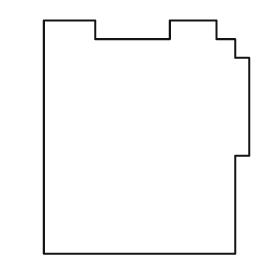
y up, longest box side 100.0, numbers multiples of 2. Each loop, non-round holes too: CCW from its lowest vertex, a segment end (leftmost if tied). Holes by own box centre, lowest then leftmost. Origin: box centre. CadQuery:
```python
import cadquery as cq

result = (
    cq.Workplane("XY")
    .moveTo(-44.0, -50.0)
    .lineTo(38.0, -50.0)
    .lineTo(38.0, -8.0)
    .lineTo(44.0, -8.0)
    .lineTo(44.0, 34.0)
    .lineTo(38.0, 34.0)
    .lineTo(38.0, 42.0)
    .lineTo(30.0, 42.0)
    .lineTo(30.0, 50.0)
    .lineTo(10.0, 50.0)
    .lineTo(10.0, 42.0)
    .lineTo(-22.0, 42.0)
    .lineTo(-22.0, 50.0)
    .lineTo(-44.0, 50.0)
    .close()
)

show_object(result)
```